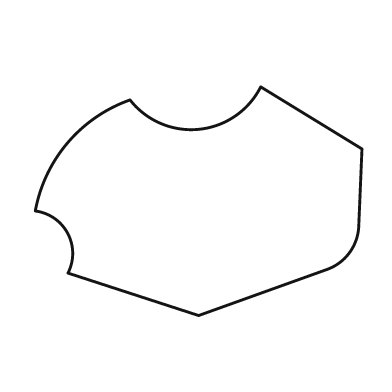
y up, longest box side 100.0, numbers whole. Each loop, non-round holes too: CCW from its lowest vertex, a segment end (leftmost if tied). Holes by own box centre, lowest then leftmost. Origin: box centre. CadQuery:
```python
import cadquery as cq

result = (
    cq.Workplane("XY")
    .moveTo(0.0, -35.0)
    .lineTo(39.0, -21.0)
    .threePointArc((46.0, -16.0), (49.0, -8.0))
    .lineTo(50.0, 16.0)
    .lineTo(19.0, 35.0)
    .threePointArc((0.0, 22.0), (-21.0, 31.0))
    .threePointArc((-40.0, 18.0), (-50.0, -3.0))
    .threePointArc((-40.0, -10.0), (-40.0, -22.0))
    .close()
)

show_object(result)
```